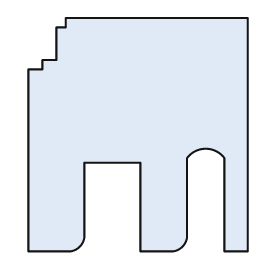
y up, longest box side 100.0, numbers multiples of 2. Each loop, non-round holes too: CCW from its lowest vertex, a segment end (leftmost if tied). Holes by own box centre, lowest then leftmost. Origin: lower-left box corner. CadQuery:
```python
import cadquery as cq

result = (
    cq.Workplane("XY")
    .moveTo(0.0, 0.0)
    .lineTo(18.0, 0.0)
    .threePointArc((22.0, 2.0), (24.0, 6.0))
    .lineTo(24.0, 38.0)
    .lineTo(48.0, 38.0)
    .lineTo(48.0, 0.0)
    .lineTo(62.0, 0.0)
    .threePointArc((66.0, 2.0), (68.0, 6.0))
    .lineTo(68.0, 40.0)
    .threePointArc((76.0, 44.0), (84.0, 40.0))
    .lineTo(84.0, 0.0)
    .lineTo(94.0, 0.0)
    .lineTo(94.0, 100.0)
    .lineTo(16.0, 100.0)
    .lineTo(16.0, 96.0)
    .lineTo(12.0, 96.0)
    .lineTo(12.0, 82.0)
    .lineTo(6.0, 82.0)
    .lineTo(6.0, 78.0)
    .lineTo(0.0, 78.0)
    .close()
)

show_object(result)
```